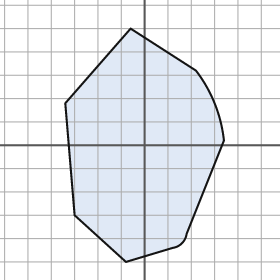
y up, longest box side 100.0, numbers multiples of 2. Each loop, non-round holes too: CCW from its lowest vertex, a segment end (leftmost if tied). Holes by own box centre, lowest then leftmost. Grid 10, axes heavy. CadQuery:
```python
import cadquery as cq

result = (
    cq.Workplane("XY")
    .moveTo(-8.0, -50.0)
    .lineTo(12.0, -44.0)
    .threePointArc((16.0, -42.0), (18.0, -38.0))
    .lineTo(34.0, 2.0)
    .threePointArc((30.0, 18.0), (22.0, 32.0))
    .lineTo(-6.0, 50.0)
    .lineTo(-34.0, 18.0)
    .lineTo(-30.0, -30.0)
    .close()
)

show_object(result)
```